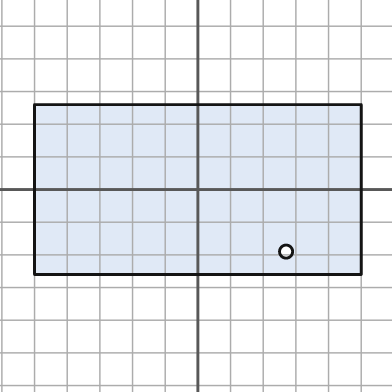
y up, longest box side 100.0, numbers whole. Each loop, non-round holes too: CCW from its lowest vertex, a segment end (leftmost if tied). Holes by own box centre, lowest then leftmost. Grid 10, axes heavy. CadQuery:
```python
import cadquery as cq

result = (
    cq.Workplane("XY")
    .moveTo(-50.0, -26.0)
    .lineTo(50.0, -26.0)
    .lineTo(50.0, 26.0)
    .lineTo(-50.0, 26.0)
    .close()
    .moveTo(27.0, -19.0)
    .circle(2.0)
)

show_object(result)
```